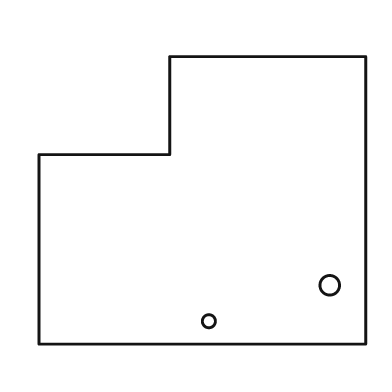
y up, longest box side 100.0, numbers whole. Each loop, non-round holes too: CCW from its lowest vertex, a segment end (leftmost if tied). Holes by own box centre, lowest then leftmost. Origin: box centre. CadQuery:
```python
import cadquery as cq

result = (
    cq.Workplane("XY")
    .moveTo(-50.0, -44.0)
    .lineTo(50.0, -44.0)
    .lineTo(50.0, 44.0)
    .lineTo(-10.0, 44.0)
    .lineTo(-10.0, 14.0)
    .lineTo(-50.0, 14.0)
    .close()
    .moveTo(2.0, -37.0)
    .circle(2.0)
    .moveTo(39.0, -26.0)
    .circle(3.0)
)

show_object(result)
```